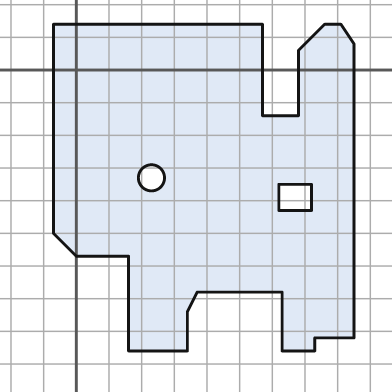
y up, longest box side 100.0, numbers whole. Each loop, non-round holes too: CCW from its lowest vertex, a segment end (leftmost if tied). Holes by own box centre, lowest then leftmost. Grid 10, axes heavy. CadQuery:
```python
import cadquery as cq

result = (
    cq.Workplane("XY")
    .moveTo(16.0, -86.0)
    .lineTo(34.0, -86.0)
    .lineTo(34.0, -74.0)
    .lineTo(37.0, -68.0)
    .lineTo(63.0, -68.0)
    .lineTo(63.0, -86.0)
    .lineTo(73.0, -86.0)
    .lineTo(73.0, -82.0)
    .lineTo(85.0, -82.0)
    .lineTo(85.0, 8.0)
    .lineTo(81.0, 14.0)
    .lineTo(76.0, 14.0)
    .lineTo(68.0, 6.0)
    .lineTo(68.0, -14.0)
    .lineTo(57.0, -14.0)
    .lineTo(57.0, 14.0)
    .lineTo(-7.0, 14.0)
    .lineTo(-7.0, -50.0)
    .lineTo(0.0, -57.0)
    .lineTo(16.0, -57.0)
    .close()
    .moveTo(62.0, -43.0)
    .lineTo(72.0, -43.0)
    .lineTo(72.0, -35.0)
    .lineTo(62.0, -35.0)
    .close()
    .moveTo(23.0, -33.0)
    .circle(4.0)
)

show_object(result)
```